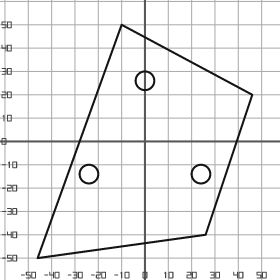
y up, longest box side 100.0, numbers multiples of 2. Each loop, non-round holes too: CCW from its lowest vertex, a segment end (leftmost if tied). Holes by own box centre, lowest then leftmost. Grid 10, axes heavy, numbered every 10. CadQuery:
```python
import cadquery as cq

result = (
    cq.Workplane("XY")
    .moveTo(-46.0, -50.0)
    .lineTo(26.0, -40.0)
    .lineTo(46.0, 20.0)
    .lineTo(-10.0, 50.0)
    .close()
    .moveTo(-24.0, -14.0)
    .circle(4.0)
    .moveTo(24.0, -14.0)
    .circle(4.0)
    .moveTo(0.0, 26.0)
    .circle(4.0)
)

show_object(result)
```